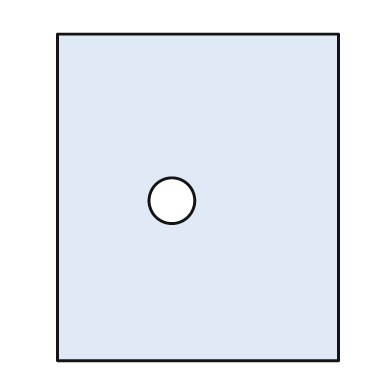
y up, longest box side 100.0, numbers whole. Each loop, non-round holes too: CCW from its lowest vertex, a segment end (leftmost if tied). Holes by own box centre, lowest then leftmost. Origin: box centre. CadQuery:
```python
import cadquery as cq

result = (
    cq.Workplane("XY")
    .moveTo(-43.0, -50.0)
    .lineTo(43.0, -50.0)
    .lineTo(43.0, 50.0)
    .lineTo(-43.0, 50.0)
    .close()
    .moveTo(-8.0, -1.0)
    .circle(7.0)
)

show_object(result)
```